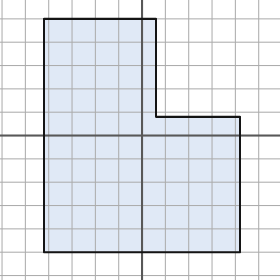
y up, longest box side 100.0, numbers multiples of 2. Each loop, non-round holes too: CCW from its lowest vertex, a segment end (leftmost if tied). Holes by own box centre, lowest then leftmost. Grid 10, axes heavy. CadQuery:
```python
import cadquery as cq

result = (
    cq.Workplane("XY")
    .moveTo(-42.0, -50.0)
    .lineTo(42.0, -50.0)
    .lineTo(42.0, 8.0)
    .lineTo(6.0, 8.0)
    .lineTo(6.0, 50.0)
    .lineTo(-42.0, 50.0)
    .close()
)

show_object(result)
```